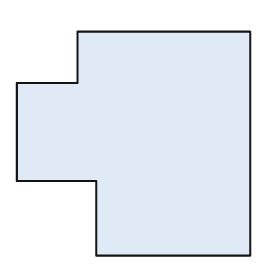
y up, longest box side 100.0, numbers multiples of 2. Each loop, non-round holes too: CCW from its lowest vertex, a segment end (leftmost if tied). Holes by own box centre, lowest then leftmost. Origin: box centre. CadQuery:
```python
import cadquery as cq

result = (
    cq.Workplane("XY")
    .moveTo(-16.0, -48.0)
    .lineTo(50.0, -48.0)
    .lineTo(50.0, 48.0)
    .lineTo(-24.0, 48.0)
    .lineTo(-24.0, 26.0)
    .lineTo(-50.0, 26.0)
    .lineTo(-50.0, -16.0)
    .lineTo(-16.0, -16.0)
    .close()
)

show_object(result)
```